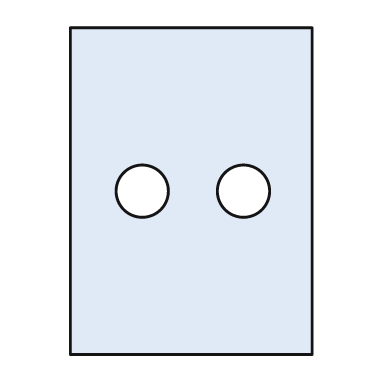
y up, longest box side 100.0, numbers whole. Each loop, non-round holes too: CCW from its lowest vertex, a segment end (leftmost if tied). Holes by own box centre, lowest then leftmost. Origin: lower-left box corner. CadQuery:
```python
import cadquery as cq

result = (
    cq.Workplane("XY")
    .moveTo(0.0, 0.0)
    .lineTo(74.0, 0.0)
    .lineTo(74.0, 100.0)
    .lineTo(0.0, 100.0)
    .close()
    .moveTo(22.0, 50.0)
    .circle(8.0)
    .moveTo(53.0, 50.0)
    .circle(8.0)
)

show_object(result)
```